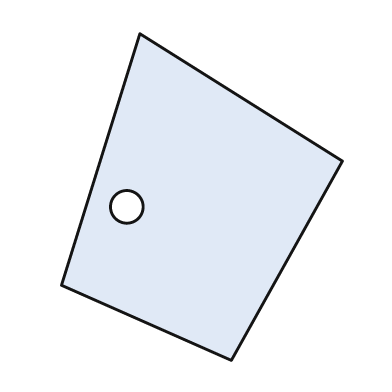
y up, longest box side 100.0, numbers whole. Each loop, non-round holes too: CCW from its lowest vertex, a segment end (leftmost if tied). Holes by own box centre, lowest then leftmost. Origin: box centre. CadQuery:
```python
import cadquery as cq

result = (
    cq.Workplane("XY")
    .moveTo(9.0, -50.0)
    .lineTo(43.0, 11.0)
    .lineTo(-19.0, 50.0)
    .lineTo(-43.0, -27.0)
    .close()
    .moveTo(-23.0, -3.0)
    .circle(5.0)
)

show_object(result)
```